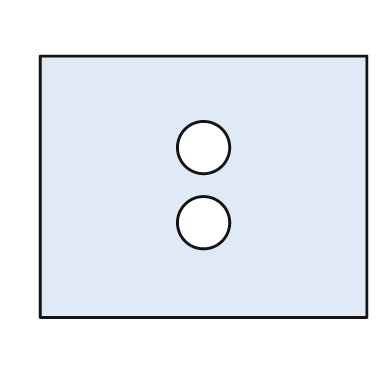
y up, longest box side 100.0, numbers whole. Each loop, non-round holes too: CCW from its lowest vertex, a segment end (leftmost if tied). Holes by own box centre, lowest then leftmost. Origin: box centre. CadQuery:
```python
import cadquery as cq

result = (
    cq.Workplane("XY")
    .moveTo(-50.0, -40.0)
    .lineTo(50.0, -40.0)
    .lineTo(50.0, 40.0)
    .lineTo(-50.0, 40.0)
    .close()
    .moveTo(0.0, -11.0)
    .circle(8.0)
    .moveTo(0.0, 12.0)
    .circle(8.0)
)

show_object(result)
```